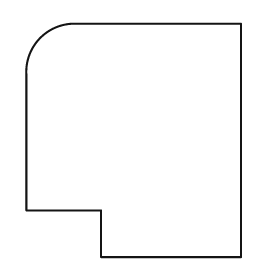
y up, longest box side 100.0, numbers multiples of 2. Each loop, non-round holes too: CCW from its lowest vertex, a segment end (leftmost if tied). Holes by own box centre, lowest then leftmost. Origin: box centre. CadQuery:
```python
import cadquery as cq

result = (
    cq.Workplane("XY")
    .moveTo(-14.0, -50.0)
    .lineTo(46.0, -50.0)
    .lineTo(46.0, 50.0)
    .lineTo(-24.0, 50.0)
    .threePointArc((-40.0, 44.0), (-46.0, 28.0))
    .lineTo(-46.0, -30.0)
    .lineTo(-14.0, -30.0)
    .close()
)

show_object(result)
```